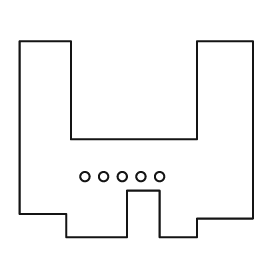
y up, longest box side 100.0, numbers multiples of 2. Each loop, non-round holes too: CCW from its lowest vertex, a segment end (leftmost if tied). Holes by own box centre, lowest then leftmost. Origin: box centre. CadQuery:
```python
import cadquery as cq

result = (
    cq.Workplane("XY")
    .moveTo(-30.0, -42.0)
    .lineTo(-4.0, -42.0)
    .lineTo(-4.0, -22.0)
    .lineTo(10.0, -22.0)
    .lineTo(10.0, -42.0)
    .lineTo(26.0, -42.0)
    .lineTo(26.0, -34.0)
    .lineTo(50.0, -34.0)
    .lineTo(50.0, 42.0)
    .lineTo(26.0, 42.0)
    .lineTo(26.0, 0.0)
    .lineTo(-28.0, 0.0)
    .lineTo(-28.0, 42.0)
    .lineTo(-50.0, 42.0)
    .lineTo(-50.0, -32.0)
    .lineTo(-30.0, -32.0)
    .close()
    .moveTo(-22.0, -16.0)
    .circle(2.0)
    .moveTo(-14.0, -16.0)
    .circle(2.0)
    .moveTo(-6.0, -16.0)
    .circle(2.0)
    .moveTo(2.0, -16.0)
    .circle(2.0)
    .moveTo(10.0, -16.0)
    .circle(2.0)
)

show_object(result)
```